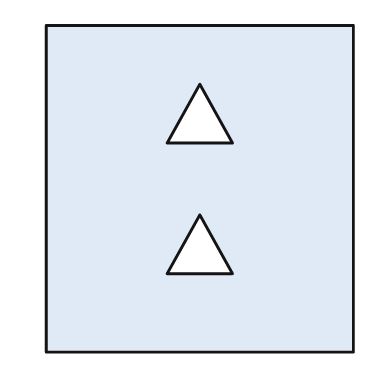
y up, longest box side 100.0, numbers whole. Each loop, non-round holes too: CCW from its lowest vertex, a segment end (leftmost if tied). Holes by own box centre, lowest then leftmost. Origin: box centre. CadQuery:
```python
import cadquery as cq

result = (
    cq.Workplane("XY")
    .moveTo(-47.0, -50.0)
    .lineTo(47.0, -50.0)
    .lineTo(47.0, 50.0)
    .lineTo(-47.0, 50.0)
    .close()
    .moveTo(-10.0, -26.0)
    .lineTo(10.0, -26.0)
    .lineTo(0.0, -8.0)
    .close()
    .moveTo(-10.0, 14.0)
    .lineTo(10.0, 14.0)
    .lineTo(0.0, 32.0)
    .close()
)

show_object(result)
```